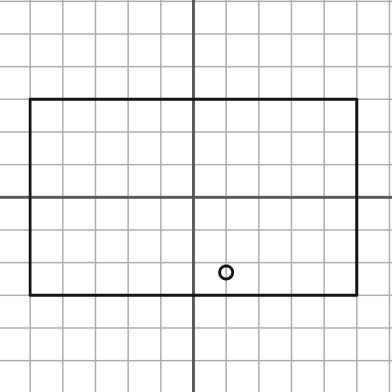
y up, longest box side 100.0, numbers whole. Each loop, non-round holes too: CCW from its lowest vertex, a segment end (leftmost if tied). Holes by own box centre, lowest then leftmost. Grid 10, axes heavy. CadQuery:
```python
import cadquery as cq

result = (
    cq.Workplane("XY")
    .moveTo(-50.0, -30.0)
    .lineTo(50.0, -30.0)
    .lineTo(50.0, 30.0)
    .lineTo(-50.0, 30.0)
    .close()
    .moveTo(10.0, -23.0)
    .circle(2.0)
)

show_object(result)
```